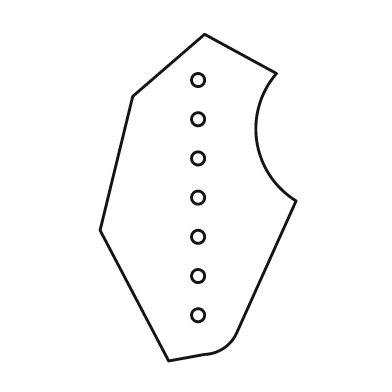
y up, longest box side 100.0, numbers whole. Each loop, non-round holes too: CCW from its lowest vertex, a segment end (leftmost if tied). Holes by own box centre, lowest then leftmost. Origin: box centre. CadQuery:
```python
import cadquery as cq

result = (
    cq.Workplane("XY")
    .moveTo(-9.0, -50.0)
    .lineTo(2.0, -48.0)
    .threePointArc((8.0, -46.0), (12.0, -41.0))
    .lineTo(30.0, -1.0)
    .threePointArc((18.0, 17.0), (24.0, 38.0))
    .lineTo(2.0, 50.0)
    .lineTo(-20.0, 31.0)
    .lineTo(-30.0, -10.0)
    .close()
    .moveTo(0.0, -36.0)
    .circle(2.0)
    .moveTo(0.0, -24.0)
    .circle(2.0)
    .moveTo(0.0, -12.0)
    .circle(2.0)
    .moveTo(0.0, 0.0)
    .circle(2.0)
    .moveTo(0.0, 12.0)
    .circle(2.0)
    .moveTo(0.0, 24.0)
    .circle(2.0)
    .moveTo(0.0, 36.0)
    .circle(2.0)
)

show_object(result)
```